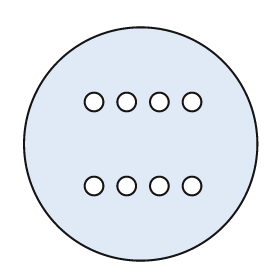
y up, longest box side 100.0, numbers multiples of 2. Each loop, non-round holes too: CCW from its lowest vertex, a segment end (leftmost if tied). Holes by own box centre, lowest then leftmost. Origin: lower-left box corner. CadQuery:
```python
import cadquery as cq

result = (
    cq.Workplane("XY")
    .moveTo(50.0, 50.0)
    .circle(50.0)
    .moveTo(30.0, 32.0)
    .circle(4.0)
    .moveTo(44.0, 32.0)
    .circle(4.0)
    .moveTo(58.0, 32.0)
    .circle(4.0)
    .moveTo(72.0, 32.0)
    .circle(4.0)
    .moveTo(30.0, 68.0)
    .circle(4.0)
    .moveTo(44.0, 68.0)
    .circle(4.0)
    .moveTo(58.0, 68.0)
    .circle(4.0)
    .moveTo(72.0, 68.0)
    .circle(4.0)
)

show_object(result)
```